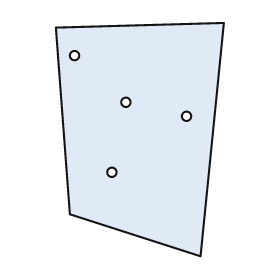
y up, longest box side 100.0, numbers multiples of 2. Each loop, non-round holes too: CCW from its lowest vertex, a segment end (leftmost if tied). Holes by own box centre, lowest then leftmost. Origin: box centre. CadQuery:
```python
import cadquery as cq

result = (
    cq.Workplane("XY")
    .moveTo(26.0, -50.0)
    .lineTo(36.0, 50.0)
    .lineTo(-36.0, 48.0)
    .lineTo(-30.0, -32.0)
    .close()
    .moveTo(-12.0, -14.0)
    .circle(2.0)
    .moveTo(20.0, 10.0)
    .circle(2.0)
    .moveTo(-6.0, 16.0)
    .circle(2.0)
    .moveTo(-28.0, 36.0)
    .circle(2.0)
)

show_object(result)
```